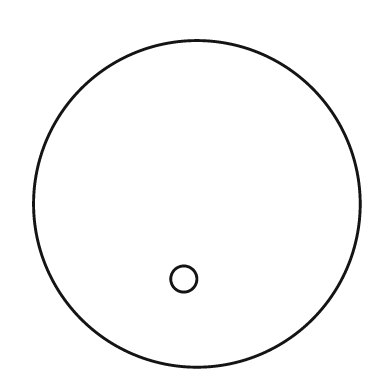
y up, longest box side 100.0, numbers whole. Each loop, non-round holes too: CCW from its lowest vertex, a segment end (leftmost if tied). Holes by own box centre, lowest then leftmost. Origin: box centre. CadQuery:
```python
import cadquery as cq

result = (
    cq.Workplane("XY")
    .moveTo(0.0, 0.0)
    .circle(50.0)
    .moveTo(-4.0, -23.0)
    .circle(4.0)
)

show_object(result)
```